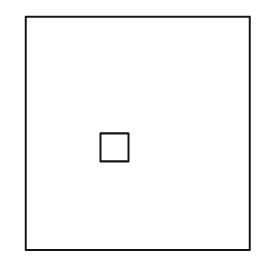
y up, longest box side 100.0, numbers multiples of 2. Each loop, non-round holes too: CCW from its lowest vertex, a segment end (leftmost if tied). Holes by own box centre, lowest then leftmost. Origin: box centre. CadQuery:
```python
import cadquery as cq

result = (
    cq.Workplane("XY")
    .moveTo(-48.0, -50.0)
    .lineTo(48.0, -50.0)
    .lineTo(48.0, 50.0)
    .lineTo(-48.0, 50.0)
    .close()
    .moveTo(-16.0, -12.0)
    .lineTo(-4.0, -12.0)
    .lineTo(-4.0, 0.0)
    .lineTo(-16.0, 0.0)
    .close()
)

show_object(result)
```